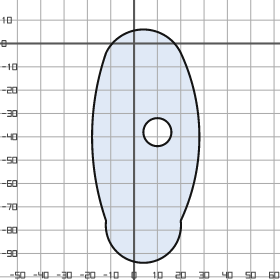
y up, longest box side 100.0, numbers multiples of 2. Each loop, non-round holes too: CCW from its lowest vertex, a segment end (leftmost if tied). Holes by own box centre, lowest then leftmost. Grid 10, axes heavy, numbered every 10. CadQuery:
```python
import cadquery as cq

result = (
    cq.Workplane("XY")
    .moveTo(-12.0, -76.0)
    .threePointArc((4.0, -94.0), (20.0, -76.0))
    .threePointArc((28.0, -40.0), (20.0, -4.0))
    .threePointArc((4.0, 6.0), (-12.0, -4.0))
    .threePointArc((-18.0, -40.0), (-12.0, -76.0))
    .close()
    .moveTo(10.0, -38.0)
    .circle(6.0)
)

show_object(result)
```